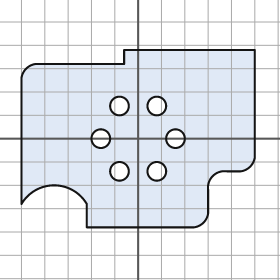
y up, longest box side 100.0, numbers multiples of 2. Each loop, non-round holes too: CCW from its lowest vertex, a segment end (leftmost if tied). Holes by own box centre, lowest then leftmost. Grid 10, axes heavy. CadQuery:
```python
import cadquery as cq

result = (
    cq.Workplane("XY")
    .moveTo(-22.0, -38.0)
    .lineTo(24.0, -38.0)
    .threePointArc((28.0, -36.0), (30.0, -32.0))
    .lineTo(30.0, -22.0)
    .threePointArc((32.0, -16.0), (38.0, -14.0))
    .lineTo(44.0, -14.0)
    .threePointArc((48.0, -12.0), (50.0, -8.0))
    .lineTo(50.0, 38.0)
    .lineTo(-6.0, 38.0)
    .lineTo(-6.0, 32.0)
    .lineTo(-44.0, 32.0)
    .threePointArc((-48.0, 30.0), (-50.0, 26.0))
    .lineTo(-50.0, -28.0)
    .threePointArc((-36.0, -20.0), (-22.0, -28.0))
    .close()
    .moveTo(-8.0, -14.0)
    .circle(4.0)
    .moveTo(8.0, -14.0)
    .circle(4.0)
    .moveTo(-16.0, 0.0)
    .circle(4.0)
    .moveTo(16.0, 0.0)
    .circle(4.0)
    .moveTo(-8.0, 14.0)
    .circle(4.0)
    .moveTo(8.0, 14.0)
    .circle(4.0)
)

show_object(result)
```